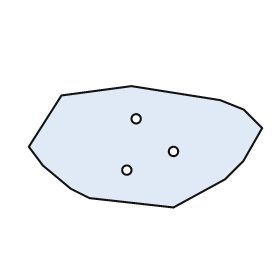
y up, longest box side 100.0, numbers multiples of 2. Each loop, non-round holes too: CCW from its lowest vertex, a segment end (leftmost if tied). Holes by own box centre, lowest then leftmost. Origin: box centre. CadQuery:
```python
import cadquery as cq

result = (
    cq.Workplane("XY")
    .moveTo(12.0, -26.0)
    .lineTo(34.0, -14.0)
    .lineTo(42.0, -6.0)
    .lineTo(50.0, 8.0)
    .lineTo(42.0, 16.0)
    .lineTo(32.0, 20.0)
    .lineTo(-6.0, 26.0)
    .lineTo(-36.0, 22.0)
    .lineTo(-50.0, 0.0)
    .lineTo(-44.0, -8.0)
    .lineTo(-32.0, -18.0)
    .lineTo(-24.0, -22.0)
    .close()
    .moveTo(-8.0, -10.0)
    .circle(2.0)
    .moveTo(12.0, -2.0)
    .circle(2.0)
    .moveTo(-4.0, 12.0)
    .circle(2.0)
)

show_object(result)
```